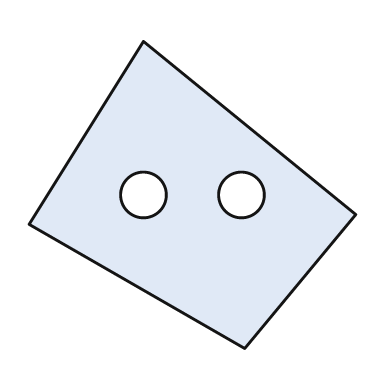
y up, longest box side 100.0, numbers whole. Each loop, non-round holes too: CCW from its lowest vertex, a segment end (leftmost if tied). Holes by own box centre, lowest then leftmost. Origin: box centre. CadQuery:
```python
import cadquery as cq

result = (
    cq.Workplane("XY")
    .moveTo(16.0, -47.0)
    .lineTo(50.0, -6.0)
    .lineTo(-15.0, 47.0)
    .lineTo(-50.0, -9.0)
    .close()
    .moveTo(-15.0, 0.0)
    .circle(7.0)
    .moveTo(15.0, 0.0)
    .circle(7.0)
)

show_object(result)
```